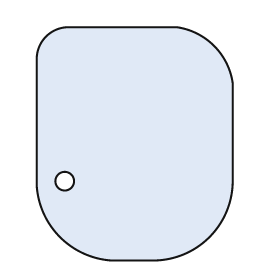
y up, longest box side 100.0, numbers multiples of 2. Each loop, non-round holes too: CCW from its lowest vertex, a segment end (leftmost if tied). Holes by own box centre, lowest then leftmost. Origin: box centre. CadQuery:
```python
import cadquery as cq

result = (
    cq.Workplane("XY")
    .moveTo(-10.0, -50.0)
    .lineTo(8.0, -50.0)
    .threePointArc((32.0, -40.0), (42.0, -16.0))
    .lineTo(42.0, 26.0)
    .threePointArc((34.0, 42.0), (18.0, 50.0))
    .lineTo(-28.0, 50.0)
    .threePointArc((-38.0, 46.0), (-42.0, 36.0))
    .lineTo(-42.0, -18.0)
    .threePointArc((-32.0, -40.0), (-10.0, -50.0))
    .close()
    .moveTo(-30.0, -16.0)
    .circle(4.0)
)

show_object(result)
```